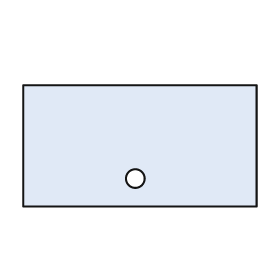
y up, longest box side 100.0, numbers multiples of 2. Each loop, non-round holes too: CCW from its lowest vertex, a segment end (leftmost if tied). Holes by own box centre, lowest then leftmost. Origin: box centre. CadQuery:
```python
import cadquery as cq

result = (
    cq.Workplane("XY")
    .moveTo(-50.0, -26.0)
    .lineTo(50.0, -26.0)
    .lineTo(50.0, 26.0)
    .lineTo(-50.0, 26.0)
    .close()
    .moveTo(-2.0, -14.0)
    .circle(4.0)
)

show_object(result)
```